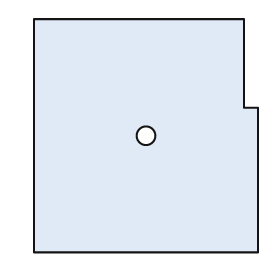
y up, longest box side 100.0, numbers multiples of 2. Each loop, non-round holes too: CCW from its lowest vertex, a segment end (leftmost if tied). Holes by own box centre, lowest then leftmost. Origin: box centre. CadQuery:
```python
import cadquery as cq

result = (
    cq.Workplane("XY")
    .moveTo(-48.0, -50.0)
    .lineTo(48.0, -50.0)
    .lineTo(48.0, 12.0)
    .lineTo(42.0, 12.0)
    .lineTo(42.0, 50.0)
    .lineTo(-48.0, 50.0)
    .close()
    .moveTo(0.0, 0.0)
    .circle(4.0)
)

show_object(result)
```